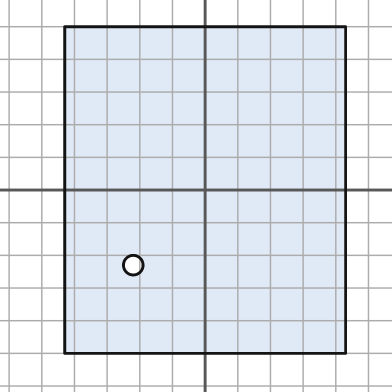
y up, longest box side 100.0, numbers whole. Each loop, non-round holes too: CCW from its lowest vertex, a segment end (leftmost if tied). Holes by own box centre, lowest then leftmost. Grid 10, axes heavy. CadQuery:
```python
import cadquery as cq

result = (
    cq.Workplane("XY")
    .moveTo(-43.0, -50.0)
    .lineTo(43.0, -50.0)
    .lineTo(43.0, 50.0)
    .lineTo(-43.0, 50.0)
    .close()
    .moveTo(-22.0, -23.0)
    .circle(3.0)
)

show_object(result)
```